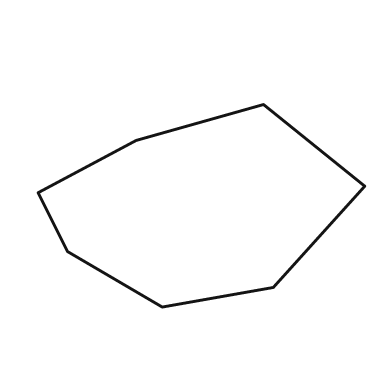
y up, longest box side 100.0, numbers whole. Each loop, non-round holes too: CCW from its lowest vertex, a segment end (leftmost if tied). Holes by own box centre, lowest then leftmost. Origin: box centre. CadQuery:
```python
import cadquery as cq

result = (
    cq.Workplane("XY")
    .moveTo(-12.0, -31.0)
    .lineTo(22.0, -25.0)
    .lineTo(50.0, 6.0)
    .lineTo(19.0, 31.0)
    .lineTo(-20.0, 20.0)
    .lineTo(-50.0, 4.0)
    .lineTo(-41.0, -14.0)
    .close()
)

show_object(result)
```